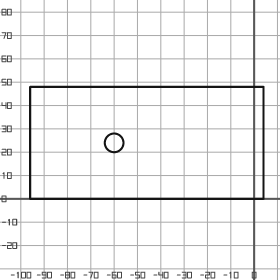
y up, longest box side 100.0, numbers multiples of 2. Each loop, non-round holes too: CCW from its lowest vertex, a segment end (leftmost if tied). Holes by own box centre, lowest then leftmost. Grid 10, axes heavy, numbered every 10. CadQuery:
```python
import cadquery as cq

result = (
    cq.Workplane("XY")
    .moveTo(-96.0, 0.0)
    .lineTo(4.0, 0.0)
    .lineTo(4.0, 48.0)
    .lineTo(-96.0, 48.0)
    .close()
    .moveTo(-60.0, 24.0)
    .circle(4.0)
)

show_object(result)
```